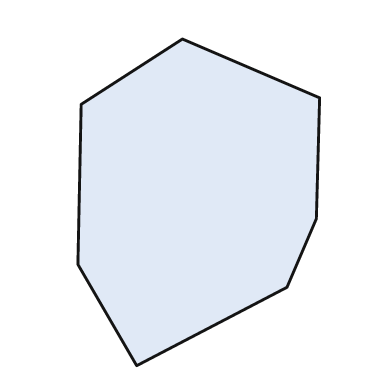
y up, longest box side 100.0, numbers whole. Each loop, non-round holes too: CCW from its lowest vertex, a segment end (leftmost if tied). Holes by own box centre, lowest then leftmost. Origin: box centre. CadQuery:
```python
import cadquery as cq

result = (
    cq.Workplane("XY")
    .moveTo(-19.0, -50.0)
    .lineTo(27.0, -26.0)
    .lineTo(36.0, -5.0)
    .lineTo(37.0, 32.0)
    .lineTo(-5.0, 50.0)
    .lineTo(-36.0, 30.0)
    .lineTo(-37.0, -19.0)
    .close()
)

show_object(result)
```